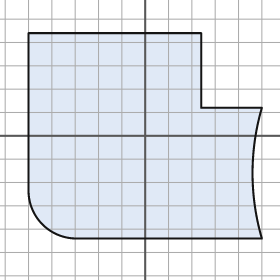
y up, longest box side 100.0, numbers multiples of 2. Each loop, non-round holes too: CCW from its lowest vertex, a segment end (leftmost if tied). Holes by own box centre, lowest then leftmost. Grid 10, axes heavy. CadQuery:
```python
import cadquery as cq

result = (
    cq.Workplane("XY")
    .moveTo(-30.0, -44.0)
    .lineTo(50.0, -44.0)
    .threePointArc((46.0, -16.0), (50.0, 12.0))
    .lineTo(24.0, 12.0)
    .lineTo(24.0, 44.0)
    .lineTo(-50.0, 44.0)
    .lineTo(-50.0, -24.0)
    .threePointArc((-44.0, -38.0), (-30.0, -44.0))
    .close()
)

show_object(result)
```